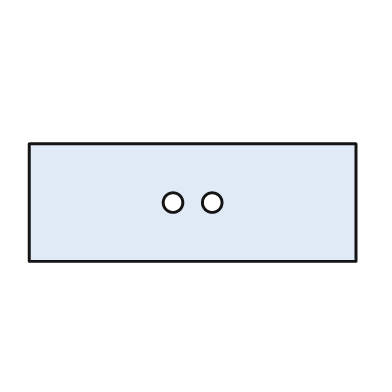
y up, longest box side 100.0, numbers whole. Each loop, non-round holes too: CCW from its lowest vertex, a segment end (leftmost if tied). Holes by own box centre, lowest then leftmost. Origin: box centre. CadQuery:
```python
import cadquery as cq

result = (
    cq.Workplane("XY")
    .moveTo(-50.0, -18.0)
    .lineTo(50.0, -18.0)
    .lineTo(50.0, 18.0)
    .lineTo(-50.0, 18.0)
    .close()
    .moveTo(-6.0, 0.0)
    .circle(3.0)
    .moveTo(6.0, 0.0)
    .circle(3.0)
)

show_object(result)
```